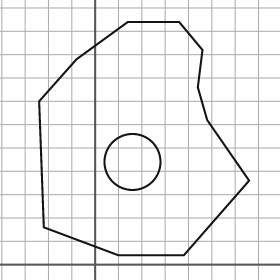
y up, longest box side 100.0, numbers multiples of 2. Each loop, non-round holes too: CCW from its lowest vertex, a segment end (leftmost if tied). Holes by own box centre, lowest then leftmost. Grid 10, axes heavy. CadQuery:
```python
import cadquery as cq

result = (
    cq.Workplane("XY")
    .moveTo(10.0, 4.0)
    .lineTo(38.0, 4.0)
    .lineTo(66.0, 36.0)
    .lineTo(48.0, 62.0)
    .lineTo(44.0, 76.0)
    .lineTo(46.0, 92.0)
    .lineTo(36.0, 104.0)
    .lineTo(14.0, 104.0)
    .lineTo(-8.0, 88.0)
    .lineTo(-24.0, 70.0)
    .lineTo(-22.0, 16.0)
    .close()
    .moveTo(16.0, 44.0)
    .circle(12.0)
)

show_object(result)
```